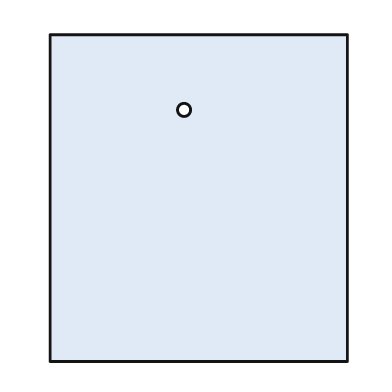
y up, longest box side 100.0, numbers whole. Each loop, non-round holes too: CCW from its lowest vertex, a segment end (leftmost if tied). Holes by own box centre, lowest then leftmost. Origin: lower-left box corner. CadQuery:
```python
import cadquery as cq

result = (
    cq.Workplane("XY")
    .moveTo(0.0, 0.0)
    .lineTo(91.0, 0.0)
    .lineTo(91.0, 100.0)
    .lineTo(0.0, 100.0)
    .close()
    .moveTo(41.0, 77.0)
    .circle(2.0)
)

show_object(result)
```